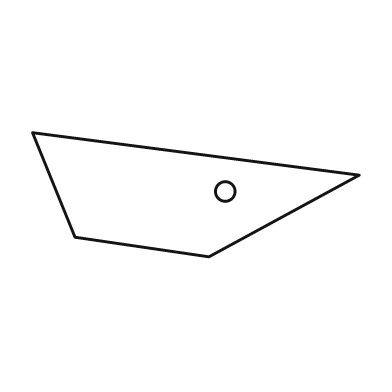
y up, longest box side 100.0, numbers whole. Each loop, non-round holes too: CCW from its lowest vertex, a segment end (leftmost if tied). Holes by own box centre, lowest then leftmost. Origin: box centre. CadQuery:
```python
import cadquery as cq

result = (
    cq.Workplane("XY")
    .moveTo(4.0, -19.0)
    .lineTo(50.0, 6.0)
    .lineTo(-50.0, 19.0)
    .lineTo(-37.0, -13.0)
    .close()
    .moveTo(9.0, 1.0)
    .circle(3.0)
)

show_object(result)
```